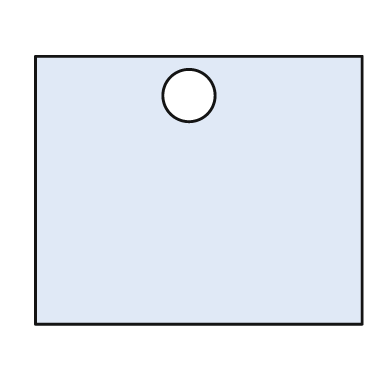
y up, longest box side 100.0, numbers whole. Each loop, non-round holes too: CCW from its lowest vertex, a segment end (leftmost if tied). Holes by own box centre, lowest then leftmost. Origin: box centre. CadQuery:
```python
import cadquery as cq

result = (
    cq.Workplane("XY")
    .moveTo(-50.0, -41.0)
    .lineTo(50.0, -41.0)
    .lineTo(50.0, 41.0)
    .lineTo(-50.0, 41.0)
    .close()
    .moveTo(-3.0, 29.0)
    .circle(8.0)
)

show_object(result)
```